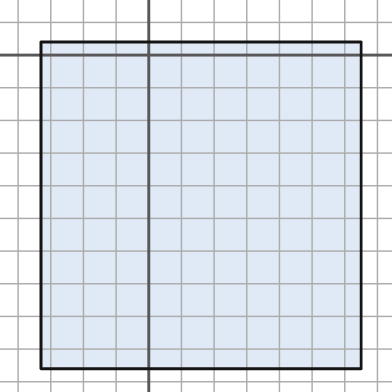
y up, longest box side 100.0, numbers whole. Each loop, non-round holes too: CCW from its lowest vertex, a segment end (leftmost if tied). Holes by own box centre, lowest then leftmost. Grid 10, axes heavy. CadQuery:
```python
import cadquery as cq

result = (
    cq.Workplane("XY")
    .moveTo(-33.0, -96.0)
    .lineTo(65.0, -96.0)
    .lineTo(65.0, 4.0)
    .lineTo(-33.0, 4.0)
    .close()
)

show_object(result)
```